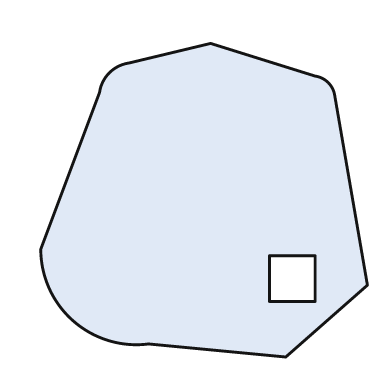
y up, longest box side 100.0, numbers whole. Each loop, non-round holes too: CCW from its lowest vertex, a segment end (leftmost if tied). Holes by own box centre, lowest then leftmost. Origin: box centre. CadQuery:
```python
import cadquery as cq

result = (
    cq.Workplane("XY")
    .moveTo(25.0, -48.0)
    .lineTo(50.0, -26.0)
    .lineTo(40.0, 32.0)
    .threePointArc((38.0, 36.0), (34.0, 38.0))
    .lineTo(2.0, 48.0)
    .lineTo(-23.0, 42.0)
    .threePointArc((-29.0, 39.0), (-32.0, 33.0))
    .lineTo(-50.0, -15.0)
    .threePointArc((-40.0, -37.0), (-17.0, -44.0))
    .close()
    .moveTo(20.0, -31.0)
    .lineTo(34.0, -31.0)
    .lineTo(34.0, -17.0)
    .lineTo(20.0, -17.0)
    .close()
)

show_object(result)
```